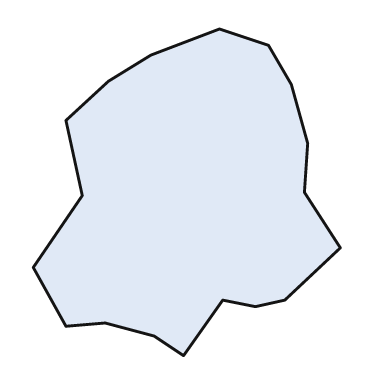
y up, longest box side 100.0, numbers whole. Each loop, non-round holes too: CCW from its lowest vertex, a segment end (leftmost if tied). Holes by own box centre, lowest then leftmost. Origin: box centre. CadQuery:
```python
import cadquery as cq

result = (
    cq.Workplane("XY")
    .moveTo(-1.0, -50.0)
    .lineTo(11.0, -33.0)
    .lineTo(21.0, -35.0)
    .lineTo(30.0, -33.0)
    .lineTo(47.0, -17.0)
    .lineTo(36.0, 0.0)
    .lineTo(37.0, 15.0)
    .lineTo(32.0, 33.0)
    .lineTo(25.0, 45.0)
    .lineTo(10.0, 50.0)
    .lineTo(-11.0, 42.0)
    .lineTo(-24.0, 34.0)
    .lineTo(-37.0, 22.0)
    .lineTo(-32.0, -1.0)
    .lineTo(-47.0, -23.0)
    .lineTo(-37.0, -41.0)
    .lineTo(-25.0, -40.0)
    .lineTo(-10.0, -44.0)
    .close()
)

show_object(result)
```